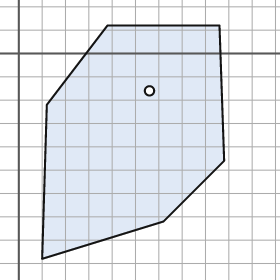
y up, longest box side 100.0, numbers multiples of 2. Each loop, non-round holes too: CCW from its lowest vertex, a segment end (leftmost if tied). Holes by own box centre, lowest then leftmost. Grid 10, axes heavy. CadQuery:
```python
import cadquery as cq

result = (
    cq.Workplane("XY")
    .moveTo(10.0, -88.0)
    .lineTo(62.0, -72.0)
    .lineTo(88.0, -46.0)
    .lineTo(86.0, 12.0)
    .lineTo(38.0, 12.0)
    .lineTo(12.0, -22.0)
    .close()
    .moveTo(56.0, -16.0)
    .circle(2.0)
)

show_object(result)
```